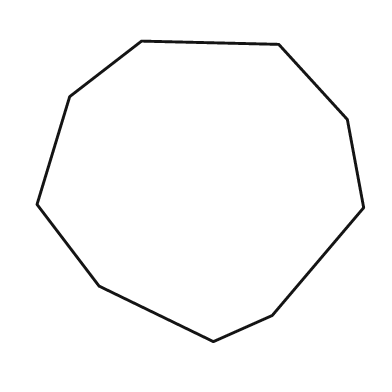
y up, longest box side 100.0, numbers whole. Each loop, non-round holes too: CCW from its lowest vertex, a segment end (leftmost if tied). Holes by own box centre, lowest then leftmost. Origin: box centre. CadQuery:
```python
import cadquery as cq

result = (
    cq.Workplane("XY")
    .moveTo(4.0, -46.0)
    .lineTo(22.0, -38.0)
    .lineTo(50.0, -5.0)
    .lineTo(45.0, 22.0)
    .lineTo(24.0, 45.0)
    .lineTo(-18.0, 46.0)
    .lineTo(-40.0, 29.0)
    .lineTo(-50.0, -4.0)
    .lineTo(-31.0, -29.0)
    .close()
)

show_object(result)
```